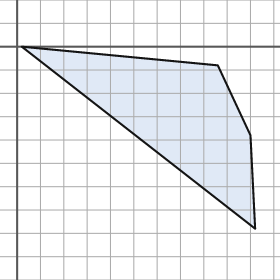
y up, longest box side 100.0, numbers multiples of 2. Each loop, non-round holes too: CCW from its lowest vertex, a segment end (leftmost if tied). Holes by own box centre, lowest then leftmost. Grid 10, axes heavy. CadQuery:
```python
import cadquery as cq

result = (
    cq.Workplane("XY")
    .moveTo(102.0, -78.0)
    .lineTo(100.0, -38.0)
    .lineTo(86.0, -8.0)
    .lineTo(2.0, 0.0)
    .close()
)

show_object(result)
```